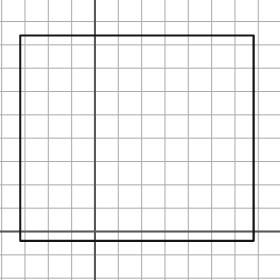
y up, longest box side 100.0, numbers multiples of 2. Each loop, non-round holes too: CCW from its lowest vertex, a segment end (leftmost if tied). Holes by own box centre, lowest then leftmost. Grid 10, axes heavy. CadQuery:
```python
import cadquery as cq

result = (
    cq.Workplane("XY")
    .moveTo(-32.0, -4.0)
    .lineTo(68.0, -4.0)
    .lineTo(68.0, 84.0)
    .lineTo(-32.0, 84.0)
    .close()
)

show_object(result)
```